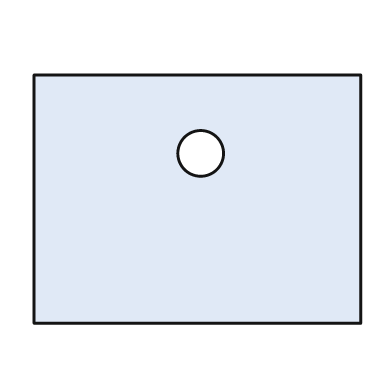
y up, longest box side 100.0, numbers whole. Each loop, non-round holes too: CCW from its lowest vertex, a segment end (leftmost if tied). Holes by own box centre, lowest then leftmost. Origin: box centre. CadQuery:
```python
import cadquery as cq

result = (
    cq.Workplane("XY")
    .moveTo(-50.0, -38.0)
    .lineTo(50.0, -38.0)
    .lineTo(50.0, 38.0)
    .lineTo(-50.0, 38.0)
    .close()
    .moveTo(1.0, 14.0)
    .circle(7.0)
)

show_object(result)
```